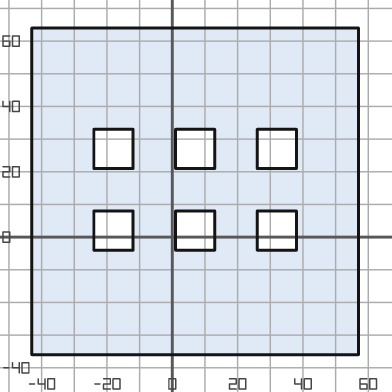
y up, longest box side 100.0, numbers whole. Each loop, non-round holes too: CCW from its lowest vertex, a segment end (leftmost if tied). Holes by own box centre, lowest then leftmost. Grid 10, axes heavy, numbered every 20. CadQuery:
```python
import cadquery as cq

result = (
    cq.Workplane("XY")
    .moveTo(-43.0, -36.0)
    .lineTo(57.0, -36.0)
    .lineTo(57.0, 64.0)
    .lineTo(-43.0, 64.0)
    .close()
    .moveTo(-24.0, -4.0)
    .lineTo(-12.0, -4.0)
    .lineTo(-12.0, 8.0)
    .lineTo(-24.0, 8.0)
    .close()
    .moveTo(1.0, -4.0)
    .lineTo(13.0, -4.0)
    .lineTo(13.0, 8.0)
    .lineTo(1.0, 8.0)
    .close()
    .moveTo(26.0, -4.0)
    .lineTo(38.0, -4.0)
    .lineTo(38.0, 8.0)
    .lineTo(26.0, 8.0)
    .close()
    .moveTo(-24.0, 21.0)
    .lineTo(-12.0, 21.0)
    .lineTo(-12.0, 33.0)
    .lineTo(-24.0, 33.0)
    .close()
    .moveTo(1.0, 21.0)
    .lineTo(13.0, 21.0)
    .lineTo(13.0, 33.0)
    .lineTo(1.0, 33.0)
    .close()
    .moveTo(26.0, 21.0)
    .lineTo(38.0, 21.0)
    .lineTo(38.0, 33.0)
    .lineTo(26.0, 33.0)
    .close()
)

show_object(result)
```